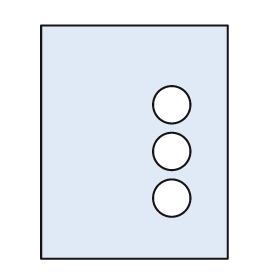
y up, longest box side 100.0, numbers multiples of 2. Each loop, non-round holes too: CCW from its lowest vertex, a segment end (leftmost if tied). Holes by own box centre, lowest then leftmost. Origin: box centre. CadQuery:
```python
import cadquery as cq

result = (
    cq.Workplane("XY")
    .moveTo(-40.0, -50.0)
    .lineTo(40.0, -50.0)
    .lineTo(40.0, 50.0)
    .lineTo(-40.0, 50.0)
    .close()
    .moveTo(16.0, -24.0)
    .circle(8.0)
    .moveTo(16.0, -4.0)
    .circle(8.0)
    .moveTo(16.0, 16.0)
    .circle(8.0)
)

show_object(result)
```